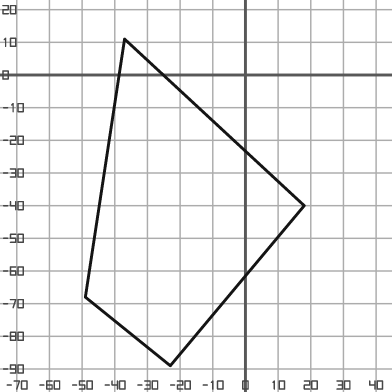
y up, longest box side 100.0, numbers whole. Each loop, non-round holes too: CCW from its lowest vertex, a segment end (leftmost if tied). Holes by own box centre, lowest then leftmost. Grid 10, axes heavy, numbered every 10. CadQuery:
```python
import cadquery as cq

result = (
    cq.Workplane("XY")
    .moveTo(-23.0, -89.0)
    .lineTo(18.0, -40.0)
    .lineTo(-37.0, 11.0)
    .lineTo(-49.0, -68.0)
    .close()
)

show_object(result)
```